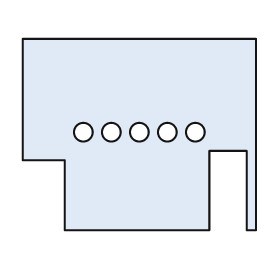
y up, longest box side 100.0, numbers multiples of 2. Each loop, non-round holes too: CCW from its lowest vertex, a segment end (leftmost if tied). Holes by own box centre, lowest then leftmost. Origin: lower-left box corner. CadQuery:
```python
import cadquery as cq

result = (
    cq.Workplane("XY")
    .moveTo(18.0, 0.0)
    .lineTo(80.0, 0.0)
    .lineTo(80.0, 34.0)
    .lineTo(96.0, 34.0)
    .lineTo(96.0, 0.0)
    .lineTo(100.0, 0.0)
    .lineTo(100.0, 82.0)
    .lineTo(0.0, 82.0)
    .lineTo(0.0, 30.0)
    .lineTo(18.0, 30.0)
    .close()
    .moveTo(26.0, 42.0)
    .circle(4.0)
    .moveTo(38.0, 42.0)
    .circle(4.0)
    .moveTo(50.0, 42.0)
    .circle(4.0)
    .moveTo(62.0, 42.0)
    .circle(4.0)
    .moveTo(74.0, 42.0)
    .circle(4.0)
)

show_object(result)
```